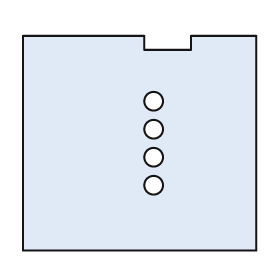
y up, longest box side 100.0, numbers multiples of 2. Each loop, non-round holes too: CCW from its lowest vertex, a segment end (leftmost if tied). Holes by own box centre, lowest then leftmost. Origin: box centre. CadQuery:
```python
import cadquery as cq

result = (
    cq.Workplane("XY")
    .moveTo(-50.0, -46.0)
    .lineTo(50.0, -46.0)
    .lineTo(50.0, 46.0)
    .lineTo(22.0, 46.0)
    .lineTo(22.0, 40.0)
    .lineTo(2.0, 40.0)
    .lineTo(2.0, 46.0)
    .lineTo(-50.0, 46.0)
    .close()
    .moveTo(6.0, -18.0)
    .circle(4.0)
    .moveTo(6.0, -6.0)
    .circle(4.0)
    .moveTo(6.0, 6.0)
    .circle(4.0)
    .moveTo(6.0, 18.0)
    .circle(4.0)
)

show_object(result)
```